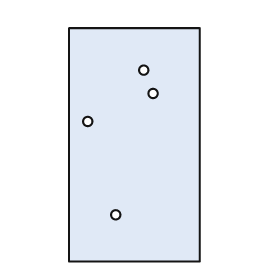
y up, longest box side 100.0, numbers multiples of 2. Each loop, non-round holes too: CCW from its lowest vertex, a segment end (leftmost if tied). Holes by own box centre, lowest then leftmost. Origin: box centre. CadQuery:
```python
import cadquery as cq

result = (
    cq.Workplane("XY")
    .moveTo(-28.0, -50.0)
    .lineTo(28.0, -50.0)
    .lineTo(28.0, 50.0)
    .lineTo(-28.0, 50.0)
    .close()
    .moveTo(-8.0, -30.0)
    .circle(2.0)
    .moveTo(-20.0, 10.0)
    .circle(2.0)
    .moveTo(8.0, 22.0)
    .circle(2.0)
    .moveTo(4.0, 32.0)
    .circle(2.0)
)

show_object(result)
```